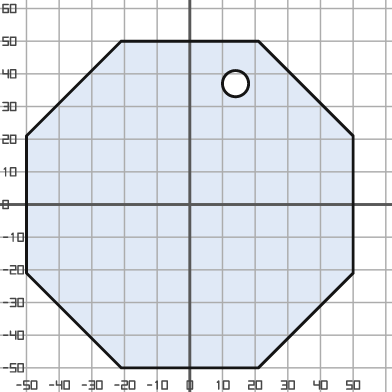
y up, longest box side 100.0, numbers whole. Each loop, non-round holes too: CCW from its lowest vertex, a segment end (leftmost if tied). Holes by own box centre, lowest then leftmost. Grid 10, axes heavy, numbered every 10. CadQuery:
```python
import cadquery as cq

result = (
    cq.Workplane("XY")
    .moveTo(-21.0, -50.0)
    .lineTo(21.0, -50.0)
    .lineTo(50.0, -21.0)
    .lineTo(50.0, 21.0)
    .lineTo(21.0, 50.0)
    .lineTo(-21.0, 50.0)
    .lineTo(-50.0, 21.0)
    .lineTo(-50.0, -21.0)
    .close()
    .moveTo(14.0, 37.0)
    .circle(4.0)
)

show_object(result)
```